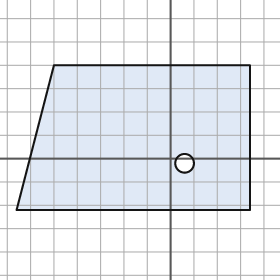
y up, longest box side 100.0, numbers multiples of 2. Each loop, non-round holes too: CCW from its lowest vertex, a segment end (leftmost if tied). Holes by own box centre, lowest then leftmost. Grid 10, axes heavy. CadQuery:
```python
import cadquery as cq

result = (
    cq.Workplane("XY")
    .moveTo(-66.0, -22.0)
    .lineTo(34.0, -22.0)
    .lineTo(34.0, 40.0)
    .lineTo(-50.0, 40.0)
    .close()
    .moveTo(6.0, -2.0)
    .circle(4.0)
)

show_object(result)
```